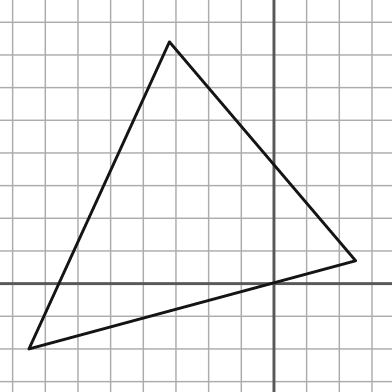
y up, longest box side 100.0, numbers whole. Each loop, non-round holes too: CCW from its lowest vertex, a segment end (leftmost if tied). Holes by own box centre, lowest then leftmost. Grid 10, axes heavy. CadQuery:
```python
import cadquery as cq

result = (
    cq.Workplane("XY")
    .moveTo(-75.0, -20.0)
    .lineTo(25.0, 7.0)
    .lineTo(-32.0, 74.0)
    .close()
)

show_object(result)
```